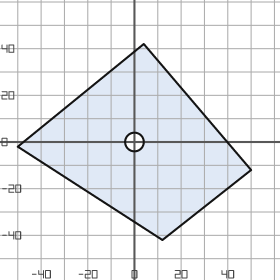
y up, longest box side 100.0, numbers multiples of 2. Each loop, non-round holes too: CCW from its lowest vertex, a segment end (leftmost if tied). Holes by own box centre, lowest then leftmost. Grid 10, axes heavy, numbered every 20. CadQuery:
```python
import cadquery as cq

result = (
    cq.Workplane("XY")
    .moveTo(12.0, -42.0)
    .lineTo(50.0, -12.0)
    .lineTo(4.0, 42.0)
    .lineTo(-50.0, -2.0)
    .close()
    .moveTo(0.0, 0.0)
    .circle(4.0)
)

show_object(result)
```